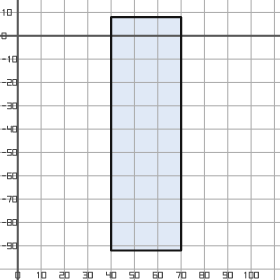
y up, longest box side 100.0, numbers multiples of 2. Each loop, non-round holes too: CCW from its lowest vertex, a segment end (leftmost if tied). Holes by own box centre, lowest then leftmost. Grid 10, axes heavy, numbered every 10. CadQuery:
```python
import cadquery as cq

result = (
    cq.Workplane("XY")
    .moveTo(40.0, -92.0)
    .lineTo(70.0, -92.0)
    .lineTo(70.0, 8.0)
    .lineTo(40.0, 8.0)
    .close()
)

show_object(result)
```